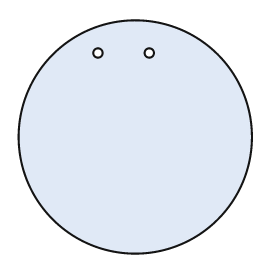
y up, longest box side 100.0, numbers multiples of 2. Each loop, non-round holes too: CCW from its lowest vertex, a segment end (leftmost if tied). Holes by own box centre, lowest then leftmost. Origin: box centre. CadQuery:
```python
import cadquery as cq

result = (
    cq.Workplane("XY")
    .moveTo(0.0, 0.0)
    .circle(50.0)
    .moveTo(-16.0, 36.0)
    .circle(2.0)
    .moveTo(6.0, 36.0)
    .circle(2.0)
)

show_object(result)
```